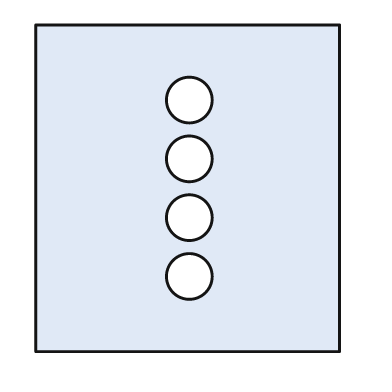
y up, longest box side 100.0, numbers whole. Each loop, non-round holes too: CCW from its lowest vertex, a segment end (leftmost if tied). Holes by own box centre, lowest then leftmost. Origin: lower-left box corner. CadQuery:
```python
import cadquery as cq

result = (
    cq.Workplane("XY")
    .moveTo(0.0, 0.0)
    .lineTo(93.0, 0.0)
    .lineTo(93.0, 100.0)
    .lineTo(0.0, 100.0)
    .close()
    .moveTo(47.0, 23.0)
    .circle(7.0)
    .moveTo(47.0, 41.0)
    .circle(7.0)
    .moveTo(47.0, 59.0)
    .circle(7.0)
    .moveTo(47.0, 77.0)
    .circle(7.0)
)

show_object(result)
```